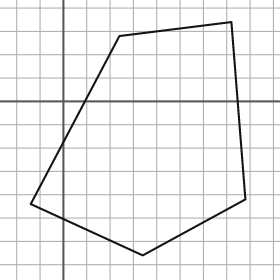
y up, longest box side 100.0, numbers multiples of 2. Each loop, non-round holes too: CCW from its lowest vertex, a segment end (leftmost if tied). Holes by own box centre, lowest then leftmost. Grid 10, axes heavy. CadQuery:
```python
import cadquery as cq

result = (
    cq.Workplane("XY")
    .moveTo(34.0, -66.0)
    .lineTo(78.0, -42.0)
    .lineTo(72.0, 34.0)
    .lineTo(24.0, 28.0)
    .lineTo(-14.0, -44.0)
    .close()
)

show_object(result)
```